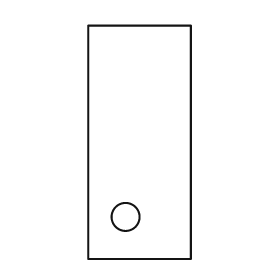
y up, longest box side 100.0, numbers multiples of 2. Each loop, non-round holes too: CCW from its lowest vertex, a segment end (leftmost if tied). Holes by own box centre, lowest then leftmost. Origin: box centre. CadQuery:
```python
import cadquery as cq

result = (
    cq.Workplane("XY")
    .moveTo(-22.0, -50.0)
    .lineTo(22.0, -50.0)
    .lineTo(22.0, 50.0)
    .lineTo(-22.0, 50.0)
    .close()
    .moveTo(-6.0, -32.0)
    .circle(6.0)
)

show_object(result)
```